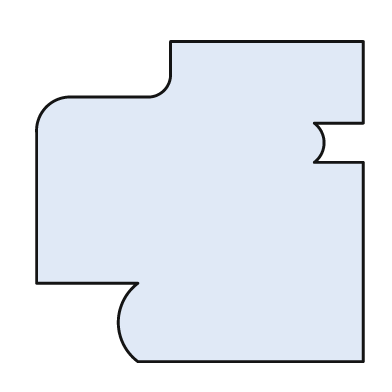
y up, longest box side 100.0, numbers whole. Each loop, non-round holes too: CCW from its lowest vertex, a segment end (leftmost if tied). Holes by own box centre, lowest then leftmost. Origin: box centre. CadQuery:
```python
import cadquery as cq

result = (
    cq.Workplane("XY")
    .moveTo(-19.0, -49.0)
    .lineTo(50.0, -49.0)
    .lineTo(50.0, 12.0)
    .lineTo(35.0, 12.0)
    .threePointArc((38.0, 18.0), (35.0, 24.0))
    .lineTo(50.0, 24.0)
    .lineTo(50.0, 49.0)
    .lineTo(-9.0, 49.0)
    .lineTo(-9.0, 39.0)
    .threePointArc((-11.0, 34.0), (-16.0, 32.0))
    .lineTo(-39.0, 32.0)
    .threePointArc((-47.0, 29.0), (-50.0, 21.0))
    .lineTo(-50.0, -25.0)
    .lineTo(-19.0, -25.0)
    .threePointArc((-25.0, -37.0), (-19.0, -49.0))
    .close()
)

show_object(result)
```